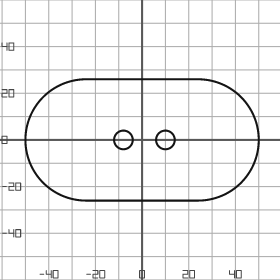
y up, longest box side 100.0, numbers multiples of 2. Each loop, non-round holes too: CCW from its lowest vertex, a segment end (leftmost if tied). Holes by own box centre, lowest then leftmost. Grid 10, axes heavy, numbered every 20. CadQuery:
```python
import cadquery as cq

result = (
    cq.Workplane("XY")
    .moveTo(-24.0, -26.0)
    .lineTo(24.0, -26.0)
    .threePointArc((50.0, 0.0), (24.0, 26.0))
    .lineTo(-24.0, 26.0)
    .threePointArc((-50.0, 0.0), (-24.0, -26.0))
    .close()
    .moveTo(-8.0, 0.0)
    .circle(4.0)
    .moveTo(10.0, 0.0)
    .circle(4.0)
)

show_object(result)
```